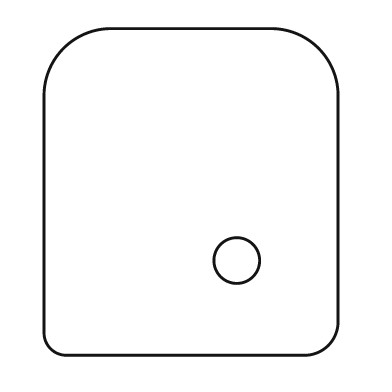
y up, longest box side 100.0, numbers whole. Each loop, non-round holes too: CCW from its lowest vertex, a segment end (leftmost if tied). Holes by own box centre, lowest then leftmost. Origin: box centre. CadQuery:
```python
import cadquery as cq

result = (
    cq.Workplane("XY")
    .moveTo(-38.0, -50.0)
    .lineTo(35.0, -50.0)
    .threePointArc((42.0, -47.0), (45.0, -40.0))
    .lineTo(45.0, 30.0)
    .threePointArc((39.0, 44.0), (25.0, 50.0))
    .lineTo(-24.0, 50.0)
    .threePointArc((-39.0, 44.0), (-45.0, 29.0))
    .lineTo(-45.0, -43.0)
    .threePointArc((-43.0, -48.0), (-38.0, -50.0))
    .close()
    .moveTo(14.0, -21.0)
    .circle(7.0)
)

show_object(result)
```